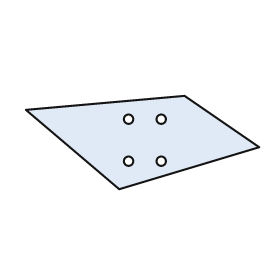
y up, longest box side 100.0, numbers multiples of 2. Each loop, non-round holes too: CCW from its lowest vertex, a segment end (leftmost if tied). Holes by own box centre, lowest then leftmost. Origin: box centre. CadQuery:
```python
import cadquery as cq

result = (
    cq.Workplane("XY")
    .moveTo(-10.0, -20.0)
    .lineTo(50.0, -2.0)
    .lineTo(18.0, 20.0)
    .lineTo(-50.0, 14.0)
    .close()
    .moveTo(-6.0, -8.0)
    .circle(2.0)
    .moveTo(8.0, -8.0)
    .circle(2.0)
    .moveTo(-6.0, 10.0)
    .circle(2.0)
    .moveTo(8.0, 10.0)
    .circle(2.0)
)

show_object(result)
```